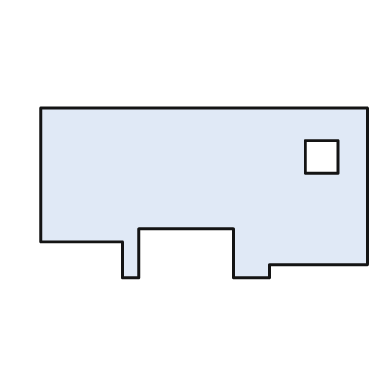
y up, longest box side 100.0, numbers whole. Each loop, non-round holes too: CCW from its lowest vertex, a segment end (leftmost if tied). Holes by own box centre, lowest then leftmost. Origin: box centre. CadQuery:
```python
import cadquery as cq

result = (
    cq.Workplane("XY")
    .moveTo(-25.0, -26.0)
    .lineTo(-20.0, -26.0)
    .lineTo(-20.0, -11.0)
    .lineTo(9.0, -11.0)
    .lineTo(9.0, -26.0)
    .lineTo(20.0, -26.0)
    .lineTo(20.0, -22.0)
    .lineTo(50.0, -22.0)
    .lineTo(50.0, 26.0)
    .lineTo(-50.0, 26.0)
    .lineTo(-50.0, -15.0)
    .lineTo(-25.0, -15.0)
    .close()
    .moveTo(31.0, 6.0)
    .lineTo(41.0, 6.0)
    .lineTo(41.0, 16.0)
    .lineTo(31.0, 16.0)
    .close()
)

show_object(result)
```